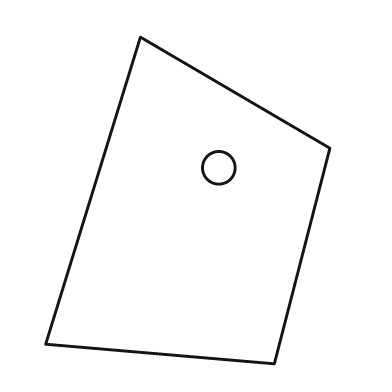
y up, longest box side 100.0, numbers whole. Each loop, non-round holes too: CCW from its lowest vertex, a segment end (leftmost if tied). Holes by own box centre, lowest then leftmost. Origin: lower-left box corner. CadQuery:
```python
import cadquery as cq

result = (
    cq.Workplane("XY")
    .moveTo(70.0, 0.0)
    .lineTo(87.0, 66.0)
    .lineTo(29.0, 100.0)
    .lineTo(0.0, 6.0)
    .close()
    .moveTo(53.0, 60.0)
    .circle(5.0)
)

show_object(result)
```